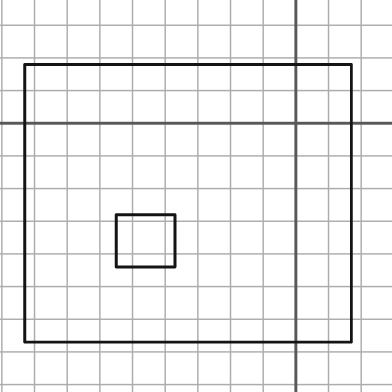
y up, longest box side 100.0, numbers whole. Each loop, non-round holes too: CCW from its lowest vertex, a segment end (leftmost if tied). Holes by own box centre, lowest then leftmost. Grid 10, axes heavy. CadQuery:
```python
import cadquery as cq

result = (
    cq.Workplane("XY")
    .moveTo(-83.0, -67.0)
    .lineTo(17.0, -67.0)
    .lineTo(17.0, 18.0)
    .lineTo(-83.0, 18.0)
    .close()
    .moveTo(-55.0, -44.0)
    .lineTo(-37.0, -44.0)
    .lineTo(-37.0, -28.0)
    .lineTo(-55.0, -28.0)
    .close()
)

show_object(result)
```